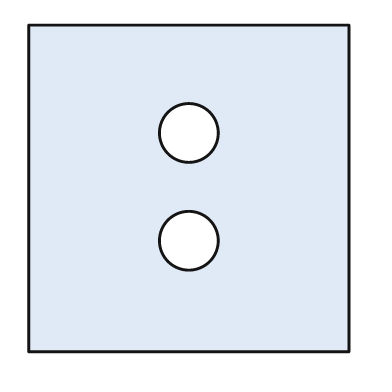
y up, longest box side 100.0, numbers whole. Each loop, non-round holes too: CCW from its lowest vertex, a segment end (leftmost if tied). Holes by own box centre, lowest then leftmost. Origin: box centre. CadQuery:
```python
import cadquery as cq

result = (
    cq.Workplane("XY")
    .moveTo(-49.0, -50.0)
    .lineTo(49.0, -50.0)
    .lineTo(49.0, 50.0)
    .lineTo(-49.0, 50.0)
    .close()
    .moveTo(0.0, -16.0)
    .circle(9.0)
    .moveTo(0.0, 17.0)
    .circle(9.0)
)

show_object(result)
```